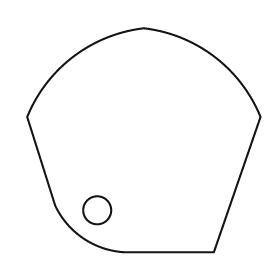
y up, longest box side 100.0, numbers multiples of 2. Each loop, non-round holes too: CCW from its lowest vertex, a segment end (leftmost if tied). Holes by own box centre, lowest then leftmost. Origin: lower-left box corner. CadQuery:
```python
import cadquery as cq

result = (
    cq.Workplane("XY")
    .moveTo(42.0, 0.0)
    .lineTo(80.0, 0.0)
    .lineTo(100.0, 58.0)
    .threePointArc((80.0, 84.0), (50.0, 96.0))
    .threePointArc((20.0, 84.0), (0.0, 58.0))
    .lineTo(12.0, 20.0)
    .threePointArc((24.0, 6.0), (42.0, 0.0))
    .close()
    .moveTo(30.0, 18.0)
    .circle(6.0)
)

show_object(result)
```